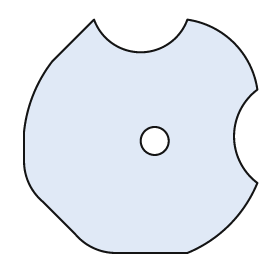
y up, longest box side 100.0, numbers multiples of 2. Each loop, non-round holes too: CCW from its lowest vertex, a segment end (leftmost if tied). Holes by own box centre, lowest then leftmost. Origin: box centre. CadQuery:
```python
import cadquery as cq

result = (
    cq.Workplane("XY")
    .moveTo(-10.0, -50.0)
    .lineTo(20.0, -50.0)
    .threePointArc((38.0, -38.0), (50.0, -20.0))
    .threePointArc((40.0, 0.0), (50.0, 20.0))
    .threePointArc((40.0, 40.0), (20.0, 50.0))
    .threePointArc((0.0, 36.0), (-20.0, 50.0))
    .lineTo(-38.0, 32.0)
    .threePointArc((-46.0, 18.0), (-50.0, 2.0))
    .lineTo(-50.0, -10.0)
    .threePointArc((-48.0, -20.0), (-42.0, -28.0))
    .lineTo(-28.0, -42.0)
    .threePointArc((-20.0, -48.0), (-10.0, -50.0))
    .close()
    .moveTo(6.0, -2.0)
    .circle(6.0)
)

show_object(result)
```